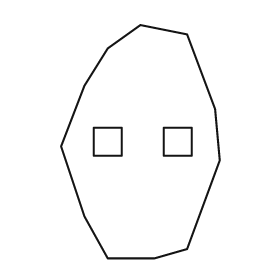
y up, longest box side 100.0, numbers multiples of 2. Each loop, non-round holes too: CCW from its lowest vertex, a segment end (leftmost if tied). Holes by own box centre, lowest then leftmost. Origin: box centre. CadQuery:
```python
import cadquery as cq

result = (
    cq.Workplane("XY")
    .moveTo(-14.0, -50.0)
    .lineTo(6.0, -50.0)
    .lineTo(20.0, -46.0)
    .lineTo(34.0, -8.0)
    .lineTo(32.0, 14.0)
    .lineTo(20.0, 46.0)
    .lineTo(0.0, 50.0)
    .lineTo(-14.0, 40.0)
    .lineTo(-24.0, 24.0)
    .lineTo(-34.0, -2.0)
    .lineTo(-24.0, -32.0)
    .close()
    .moveTo(-20.0, -6.0)
    .lineTo(-8.0, -6.0)
    .lineTo(-8.0, 6.0)
    .lineTo(-20.0, 6.0)
    .close()
    .moveTo(10.0, -6.0)
    .lineTo(22.0, -6.0)
    .lineTo(22.0, 6.0)
    .lineTo(10.0, 6.0)
    .close()
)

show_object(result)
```